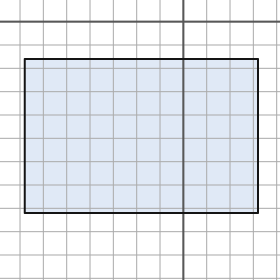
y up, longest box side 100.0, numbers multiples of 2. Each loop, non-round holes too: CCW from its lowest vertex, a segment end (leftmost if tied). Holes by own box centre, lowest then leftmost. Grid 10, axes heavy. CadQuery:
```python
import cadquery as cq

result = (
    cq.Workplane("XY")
    .moveTo(-68.0, -82.0)
    .lineTo(32.0, -82.0)
    .lineTo(32.0, -16.0)
    .lineTo(-68.0, -16.0)
    .close()
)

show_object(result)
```